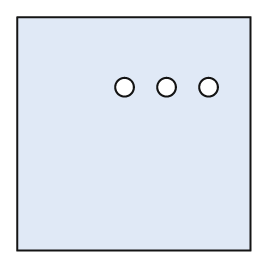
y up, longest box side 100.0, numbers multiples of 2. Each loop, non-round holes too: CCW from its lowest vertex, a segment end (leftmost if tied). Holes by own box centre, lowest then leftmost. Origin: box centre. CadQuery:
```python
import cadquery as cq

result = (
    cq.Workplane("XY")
    .moveTo(-50.0, -50.0)
    .lineTo(50.0, -50.0)
    .lineTo(50.0, 50.0)
    .lineTo(-50.0, 50.0)
    .close()
    .moveTo(-4.0, 20.0)
    .circle(4.0)
    .moveTo(14.0, 20.0)
    .circle(4.0)
    .moveTo(32.0, 20.0)
    .circle(4.0)
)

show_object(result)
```